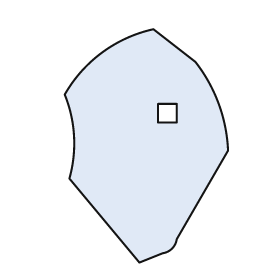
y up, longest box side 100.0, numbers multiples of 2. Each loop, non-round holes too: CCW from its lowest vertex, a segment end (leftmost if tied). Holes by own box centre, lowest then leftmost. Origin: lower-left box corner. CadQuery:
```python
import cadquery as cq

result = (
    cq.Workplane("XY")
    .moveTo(32.0, 0.0)
    .lineTo(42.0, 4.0)
    .threePointArc((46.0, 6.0), (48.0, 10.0))
    .lineTo(70.0, 48.0)
    .threePointArc((66.0, 68.0), (56.0, 86.0))
    .lineTo(38.0, 100.0)
    .threePointArc((16.0, 90.0), (0.0, 72.0))
    .threePointArc((4.0, 54.0), (2.0, 36.0))
    .close()
    .moveTo(40.0, 60.0)
    .lineTo(48.0, 60.0)
    .lineTo(48.0, 68.0)
    .lineTo(40.0, 68.0)
    .close()
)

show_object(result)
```